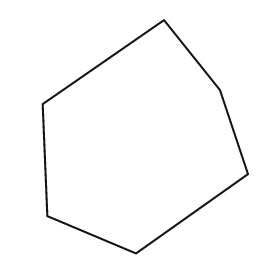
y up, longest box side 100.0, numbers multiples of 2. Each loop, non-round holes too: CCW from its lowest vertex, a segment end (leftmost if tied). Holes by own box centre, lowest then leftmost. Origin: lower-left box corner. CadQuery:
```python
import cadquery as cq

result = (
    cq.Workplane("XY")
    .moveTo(40.0, 0.0)
    .lineTo(88.0, 34.0)
    .lineTo(76.0, 70.0)
    .lineTo(52.0, 100.0)
    .lineTo(0.0, 64.0)
    .lineTo(2.0, 16.0)
    .close()
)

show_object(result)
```